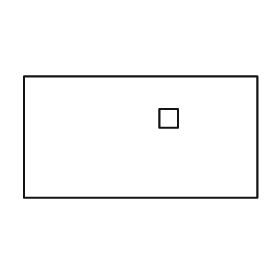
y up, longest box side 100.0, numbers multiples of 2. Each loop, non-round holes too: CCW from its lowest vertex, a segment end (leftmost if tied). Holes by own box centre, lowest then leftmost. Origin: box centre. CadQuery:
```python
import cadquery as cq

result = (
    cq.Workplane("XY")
    .moveTo(-50.0, -26.0)
    .lineTo(50.0, -26.0)
    .lineTo(50.0, 26.0)
    .lineTo(-50.0, 26.0)
    .close()
    .moveTo(8.0, 4.0)
    .lineTo(16.0, 4.0)
    .lineTo(16.0, 12.0)
    .lineTo(8.0, 12.0)
    .close()
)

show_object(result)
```